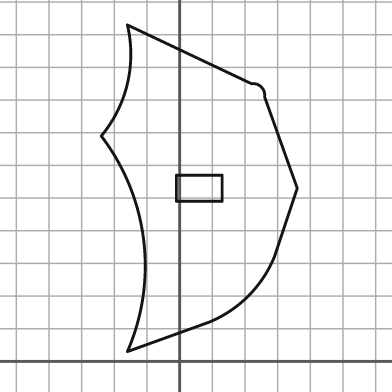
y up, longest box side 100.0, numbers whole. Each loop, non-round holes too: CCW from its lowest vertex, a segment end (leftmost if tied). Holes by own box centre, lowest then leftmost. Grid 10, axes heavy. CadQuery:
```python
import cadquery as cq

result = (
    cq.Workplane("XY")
    .moveTo(-16.0, 3.0)
    .lineTo(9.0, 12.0)
    .threePointArc((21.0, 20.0), (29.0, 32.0))
    .lineTo(36.0, 53.0)
    .lineTo(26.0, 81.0)
    .threePointArc((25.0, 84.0), (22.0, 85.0))
    .lineTo(-16.0, 103.0)
    .threePointArc((-16.0, 85.0), (-24.0, 69.0))
    .threePointArc((-11.0, 37.0), (-16.0, 3.0))
    .close()
    .moveTo(-1.0, 49.0)
    .lineTo(13.0, 49.0)
    .lineTo(13.0, 57.0)
    .lineTo(-1.0, 57.0)
    .close()
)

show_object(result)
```